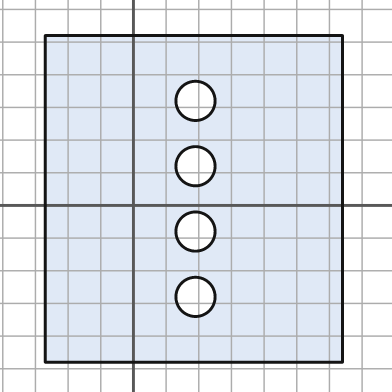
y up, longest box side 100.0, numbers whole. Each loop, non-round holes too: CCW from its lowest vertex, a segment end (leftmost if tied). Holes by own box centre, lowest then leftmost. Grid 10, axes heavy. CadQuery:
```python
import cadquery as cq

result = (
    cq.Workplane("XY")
    .moveTo(-27.0, -48.0)
    .lineTo(64.0, -48.0)
    .lineTo(64.0, 52.0)
    .lineTo(-27.0, 52.0)
    .close()
    .moveTo(19.0, -28.0)
    .circle(6.0)
    .moveTo(19.0, -8.0)
    .circle(6.0)
    .moveTo(19.0, 12.0)
    .circle(6.0)
    .moveTo(19.0, 32.0)
    .circle(6.0)
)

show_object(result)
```